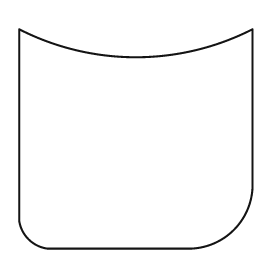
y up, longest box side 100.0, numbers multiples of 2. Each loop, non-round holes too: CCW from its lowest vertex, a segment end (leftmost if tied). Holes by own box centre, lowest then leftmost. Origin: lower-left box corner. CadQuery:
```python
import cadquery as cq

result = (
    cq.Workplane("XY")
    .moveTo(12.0, 0.0)
    .lineTo(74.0, 0.0)
    .threePointArc((92.0, 8.0), (100.0, 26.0))
    .lineTo(100.0, 94.0)
    .threePointArc((50.0, 82.0), (0.0, 94.0))
    .lineTo(0.0, 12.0)
    .threePointArc((4.0, 4.0), (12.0, 0.0))
    .close()
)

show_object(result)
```